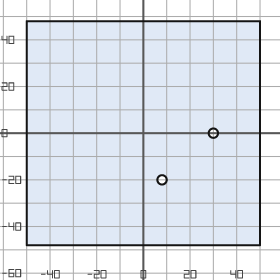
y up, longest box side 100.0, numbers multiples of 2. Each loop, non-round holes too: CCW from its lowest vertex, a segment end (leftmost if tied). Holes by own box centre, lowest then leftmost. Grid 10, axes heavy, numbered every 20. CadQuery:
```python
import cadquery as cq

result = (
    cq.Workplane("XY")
    .moveTo(-50.0, -48.0)
    .lineTo(50.0, -48.0)
    .lineTo(50.0, 48.0)
    .lineTo(-50.0, 48.0)
    .close()
    .moveTo(8.0, -20.0)
    .circle(2.0)
    .moveTo(30.0, 0.0)
    .circle(2.0)
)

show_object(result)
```